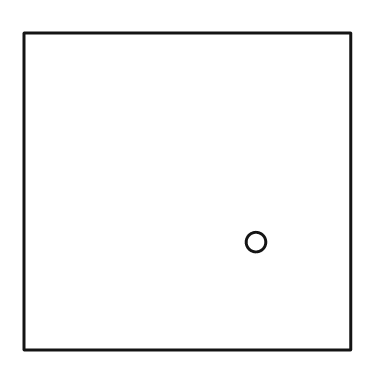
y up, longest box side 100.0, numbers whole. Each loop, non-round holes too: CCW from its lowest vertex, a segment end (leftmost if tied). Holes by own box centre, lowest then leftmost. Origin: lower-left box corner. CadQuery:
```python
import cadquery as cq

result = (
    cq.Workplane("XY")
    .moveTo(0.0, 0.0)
    .lineTo(100.0, 0.0)
    .lineTo(100.0, 97.0)
    .lineTo(0.0, 97.0)
    .close()
    .moveTo(71.0, 33.0)
    .circle(3.0)
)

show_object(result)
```